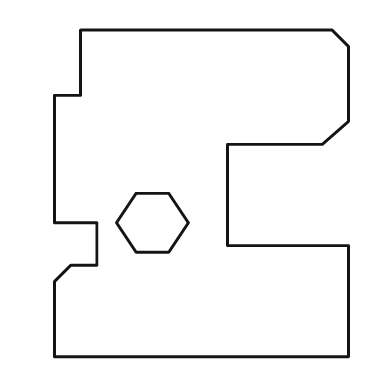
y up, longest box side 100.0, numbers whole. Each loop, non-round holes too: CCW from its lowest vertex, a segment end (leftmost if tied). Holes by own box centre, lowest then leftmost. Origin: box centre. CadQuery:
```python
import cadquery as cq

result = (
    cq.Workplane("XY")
    .moveTo(-45.0, -50.0)
    .lineTo(45.0, -50.0)
    .lineTo(45.0, -16.0)
    .lineTo(8.0, -16.0)
    .lineTo(8.0, 15.0)
    .lineTo(37.0, 15.0)
    .lineTo(45.0, 22.0)
    .lineTo(45.0, 45.0)
    .lineTo(40.0, 50.0)
    .lineTo(-37.0, 50.0)
    .lineTo(-37.0, 30.0)
    .lineTo(-45.0, 30.0)
    .lineTo(-45.0, -9.0)
    .lineTo(-32.0, -9.0)
    .lineTo(-32.0, -22.0)
    .lineTo(-40.0, -22.0)
    .lineTo(-45.0, -27.0)
    .close()
    .moveTo(-20.0, -18.0)
    .lineTo(-10.0, -18.0)
    .lineTo(-4.0, -9.0)
    .lineTo(-10.0, 0.0)
    .lineTo(-20.0, 0.0)
    .lineTo(-26.0, -9.0)
    .close()
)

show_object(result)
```